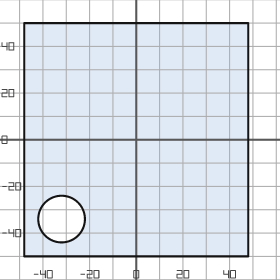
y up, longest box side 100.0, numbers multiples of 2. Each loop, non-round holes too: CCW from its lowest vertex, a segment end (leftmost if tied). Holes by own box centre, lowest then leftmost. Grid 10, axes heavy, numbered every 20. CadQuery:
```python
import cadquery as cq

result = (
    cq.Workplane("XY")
    .moveTo(-48.0, -50.0)
    .lineTo(48.0, -50.0)
    .lineTo(48.0, 50.0)
    .lineTo(-48.0, 50.0)
    .close()
    .moveTo(-32.0, -34.0)
    .circle(10.0)
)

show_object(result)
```